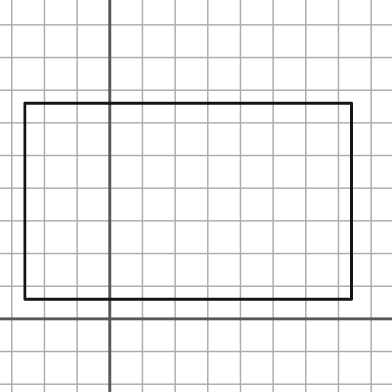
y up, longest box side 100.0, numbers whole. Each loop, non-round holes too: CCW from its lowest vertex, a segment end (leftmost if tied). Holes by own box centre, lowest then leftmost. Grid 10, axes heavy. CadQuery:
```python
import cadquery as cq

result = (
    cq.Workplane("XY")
    .moveTo(-26.0, 6.0)
    .lineTo(74.0, 6.0)
    .lineTo(74.0, 66.0)
    .lineTo(-26.0, 66.0)
    .close()
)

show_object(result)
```